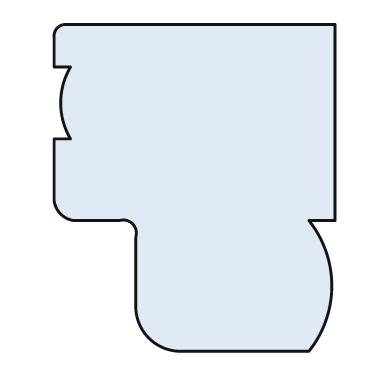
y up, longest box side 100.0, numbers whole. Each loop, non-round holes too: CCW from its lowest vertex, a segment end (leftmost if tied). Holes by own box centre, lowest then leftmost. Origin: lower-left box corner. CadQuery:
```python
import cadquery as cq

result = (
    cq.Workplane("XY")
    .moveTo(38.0, 0.0)
    .lineTo(78.0, 0.0)
    .threePointArc((85.0, 20.0), (78.0, 40.0))
    .lineTo(86.0, 40.0)
    .lineTo(86.0, 100.0)
    .lineTo(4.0, 100.0)
    .threePointArc((1.0, 99.0), (0.0, 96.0))
    .lineTo(0.0, 87.0)
    .lineTo(5.0, 87.0)
    .threePointArc((2.0, 76.0), (5.0, 65.0))
    .lineTo(0.0, 65.0)
    .lineTo(0.0, 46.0)
    .threePointArc((2.0, 42.0), (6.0, 40.0))
    .lineTo(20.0, 40.0)
    .threePointArc((24.0, 39.0), (25.0, 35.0))
    .lineTo(25.0, 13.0)
    .threePointArc((29.0, 4.0), (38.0, 0.0))
    .close()
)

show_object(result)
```